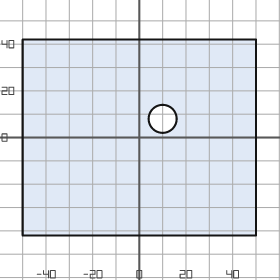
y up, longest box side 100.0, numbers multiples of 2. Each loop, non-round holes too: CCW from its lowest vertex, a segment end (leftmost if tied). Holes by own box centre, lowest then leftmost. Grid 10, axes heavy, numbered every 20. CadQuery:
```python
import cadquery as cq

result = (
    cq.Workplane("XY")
    .moveTo(-50.0, -42.0)
    .lineTo(50.0, -42.0)
    .lineTo(50.0, 42.0)
    .lineTo(-50.0, 42.0)
    .close()
    .moveTo(10.0, 8.0)
    .circle(6.0)
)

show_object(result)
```